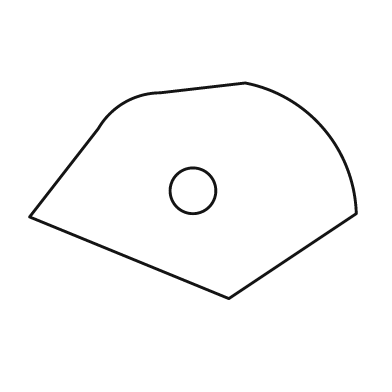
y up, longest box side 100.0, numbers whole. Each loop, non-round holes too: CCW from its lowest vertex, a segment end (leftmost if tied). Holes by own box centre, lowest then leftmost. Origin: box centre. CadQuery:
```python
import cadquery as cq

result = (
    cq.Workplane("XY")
    .moveTo(11.0, -33.0)
    .lineTo(50.0, -7.0)
    .threePointArc((40.0, 19.0), (16.0, 33.0))
    .lineTo(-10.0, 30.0)
    .threePointArc((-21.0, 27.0), (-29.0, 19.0))
    .lineTo(-50.0, -8.0)
    .close()
    .moveTo(0.0, 0.0)
    .circle(7.0)
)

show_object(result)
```